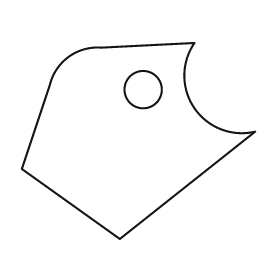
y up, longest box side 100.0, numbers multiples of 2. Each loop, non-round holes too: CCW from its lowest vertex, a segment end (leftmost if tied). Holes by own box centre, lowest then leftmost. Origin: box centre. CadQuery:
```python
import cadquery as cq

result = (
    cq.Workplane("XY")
    .moveTo(-8.0, -42.0)
    .lineTo(50.0, 4.0)
    .threePointArc((24.0, 14.0), (24.0, 42.0))
    .lineTo(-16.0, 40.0)
    .threePointArc((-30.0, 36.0), (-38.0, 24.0))
    .lineTo(-50.0, -12.0)
    .close()
    .moveTo(2.0, 22.0)
    .circle(8.0)
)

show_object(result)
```